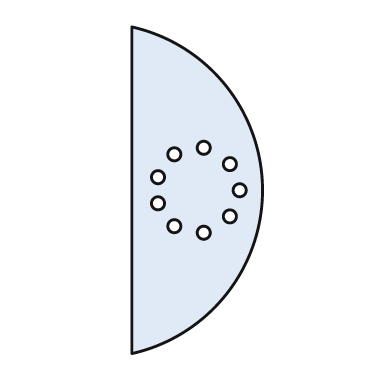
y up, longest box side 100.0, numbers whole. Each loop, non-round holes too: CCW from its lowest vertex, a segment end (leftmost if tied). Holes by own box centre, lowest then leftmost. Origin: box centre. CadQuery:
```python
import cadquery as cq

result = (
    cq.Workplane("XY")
    .moveTo(-20.0, -50.0)
    .threePointArc((20.0, 0.0), (-20.0, 50.0))
    .close()
    .moveTo(2.0, -13.0)
    .circle(2.0)
    .moveTo(-7.0, -11.0)
    .circle(2.0)
    .moveTo(10.0, -8.0)
    .circle(2.0)
    .moveTo(-12.0, -4.0)
    .circle(2.0)
    .moveTo(13.0, 0.0)
    .circle(2.0)
    .moveTo(-12.0, 4.0)
    .circle(2.0)
    .moveTo(10.0, 8.0)
    .circle(2.0)
    .moveTo(-7.0, 11.0)
    .circle(2.0)
    .moveTo(2.0, 13.0)
    .circle(2.0)
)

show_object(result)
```